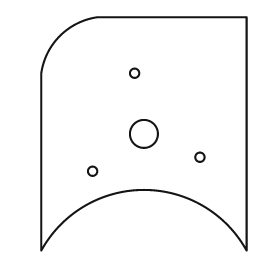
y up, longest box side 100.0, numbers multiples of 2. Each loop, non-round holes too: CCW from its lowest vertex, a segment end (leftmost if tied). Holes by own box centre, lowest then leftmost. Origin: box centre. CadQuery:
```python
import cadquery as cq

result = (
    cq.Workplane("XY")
    .moveTo(-44.0, -50.0)
    .threePointArc((0.0, -24.0), (44.0, -50.0))
    .lineTo(44.0, 50.0)
    .lineTo(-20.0, 50.0)
    .threePointArc((-36.0, 42.0), (-44.0, 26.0))
    .close()
    .moveTo(-22.0, -16.0)
    .circle(2.0)
    .moveTo(24.0, -10.0)
    .circle(2.0)
    .moveTo(0.0, 0.0)
    .circle(6.0)
    .moveTo(-4.0, 26.0)
    .circle(2.0)
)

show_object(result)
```